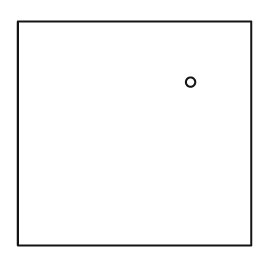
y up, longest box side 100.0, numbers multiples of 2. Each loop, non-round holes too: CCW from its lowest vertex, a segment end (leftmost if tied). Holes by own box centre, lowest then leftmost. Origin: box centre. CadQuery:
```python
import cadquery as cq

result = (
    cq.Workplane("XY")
    .moveTo(-50.0, -48.0)
    .lineTo(50.0, -48.0)
    .lineTo(50.0, 48.0)
    .lineTo(-50.0, 48.0)
    .close()
    .moveTo(24.0, 22.0)
    .circle(2.0)
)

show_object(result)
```